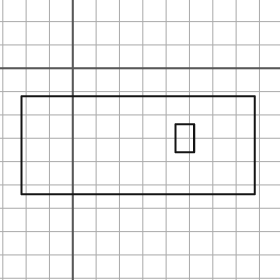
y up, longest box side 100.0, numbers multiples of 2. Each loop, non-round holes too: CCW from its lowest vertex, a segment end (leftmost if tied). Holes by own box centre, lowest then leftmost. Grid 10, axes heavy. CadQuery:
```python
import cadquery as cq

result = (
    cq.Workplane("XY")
    .moveTo(-22.0, -54.0)
    .lineTo(78.0, -54.0)
    .lineTo(78.0, -12.0)
    .lineTo(-22.0, -12.0)
    .close()
    .moveTo(44.0, -36.0)
    .lineTo(52.0, -36.0)
    .lineTo(52.0, -24.0)
    .lineTo(44.0, -24.0)
    .close()
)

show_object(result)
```